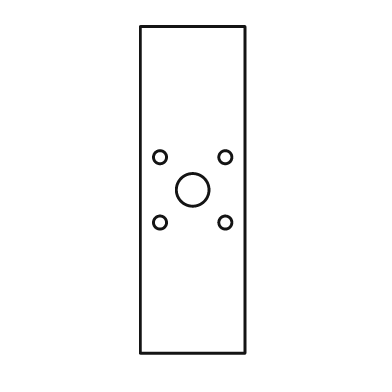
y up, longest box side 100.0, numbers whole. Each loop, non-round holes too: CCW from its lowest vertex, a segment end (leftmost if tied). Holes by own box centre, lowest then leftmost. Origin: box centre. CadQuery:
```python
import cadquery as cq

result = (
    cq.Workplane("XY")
    .moveTo(-16.0, -50.0)
    .lineTo(16.0, -50.0)
    .lineTo(16.0, 50.0)
    .lineTo(-16.0, 50.0)
    .close()
    .moveTo(-10.0, -10.0)
    .circle(2.0)
    .moveTo(10.0, -10.0)
    .circle(2.0)
    .moveTo(0.0, 0.0)
    .circle(5.0)
    .moveTo(-10.0, 10.0)
    .circle(2.0)
    .moveTo(10.0, 10.0)
    .circle(2.0)
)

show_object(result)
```